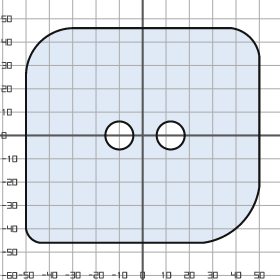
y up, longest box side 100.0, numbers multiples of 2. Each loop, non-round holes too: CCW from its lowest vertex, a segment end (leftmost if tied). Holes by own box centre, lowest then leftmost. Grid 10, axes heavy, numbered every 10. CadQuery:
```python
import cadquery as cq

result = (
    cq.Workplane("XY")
    .moveTo(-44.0, -46.0)
    .lineTo(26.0, -46.0)
    .threePointArc((42.0, -38.0), (50.0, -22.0))
    .lineTo(50.0, 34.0)
    .threePointArc((46.0, 42.0), (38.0, 46.0))
    .lineTo(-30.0, 46.0)
    .threePointArc((-44.0, 40.0), (-50.0, 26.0))
    .lineTo(-50.0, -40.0)
    .threePointArc((-48.0, -44.0), (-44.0, -46.0))
    .close()
    .moveTo(-10.0, 0.0)
    .circle(6.0)
    .moveTo(12.0, 0.0)
    .circle(6.0)
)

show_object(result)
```